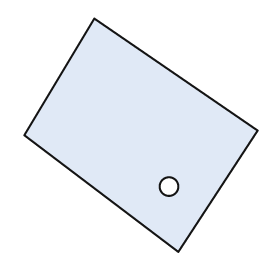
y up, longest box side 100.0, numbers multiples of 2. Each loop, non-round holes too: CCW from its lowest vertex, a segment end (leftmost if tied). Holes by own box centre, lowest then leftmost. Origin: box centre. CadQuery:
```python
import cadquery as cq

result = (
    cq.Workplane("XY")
    .moveTo(16.0, -50.0)
    .lineTo(50.0, 2.0)
    .lineTo(-20.0, 50.0)
    .lineTo(-50.0, 0.0)
    .close()
    .moveTo(12.0, -22.0)
    .circle(4.0)
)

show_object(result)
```